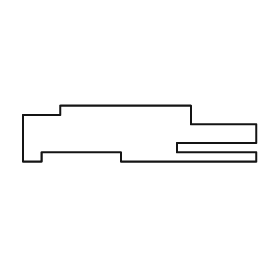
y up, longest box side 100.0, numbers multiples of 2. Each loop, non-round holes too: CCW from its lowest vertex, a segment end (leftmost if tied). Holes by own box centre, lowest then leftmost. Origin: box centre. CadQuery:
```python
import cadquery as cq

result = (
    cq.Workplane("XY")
    .moveTo(-50.0, -12.0)
    .lineTo(-42.0, -12.0)
    .lineTo(-42.0, -8.0)
    .lineTo(-8.0, -8.0)
    .lineTo(-8.0, -12.0)
    .lineTo(50.0, -12.0)
    .lineTo(50.0, -8.0)
    .lineTo(16.0, -8.0)
    .lineTo(16.0, -4.0)
    .lineTo(50.0, -4.0)
    .lineTo(50.0, 4.0)
    .lineTo(22.0, 4.0)
    .lineTo(22.0, 12.0)
    .lineTo(-34.0, 12.0)
    .lineTo(-34.0, 8.0)
    .lineTo(-50.0, 8.0)
    .close()
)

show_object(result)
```